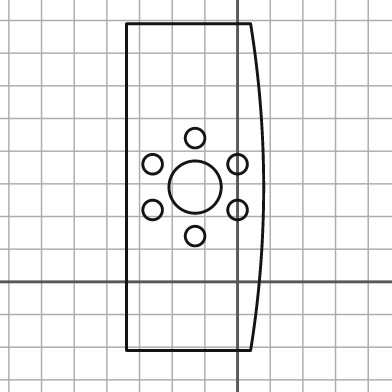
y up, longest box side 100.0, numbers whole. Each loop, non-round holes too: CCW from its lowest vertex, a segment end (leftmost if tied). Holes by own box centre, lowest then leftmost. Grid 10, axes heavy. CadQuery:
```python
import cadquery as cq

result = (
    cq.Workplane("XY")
    .moveTo(-34.0, -21.0)
    .lineTo(4.0, -21.0)
    .threePointArc((8.0, 29.0), (4.0, 79.0))
    .lineTo(-34.0, 79.0)
    .close()
    .moveTo(-13.0, 14.0)
    .circle(3.0)
    .moveTo(-26.0, 22.0)
    .circle(3.0)
    .moveTo(0.0, 22.0)
    .circle(3.0)
    .moveTo(-13.0, 29.0)
    .circle(8.0)
    .moveTo(-26.0, 36.0)
    .circle(3.0)
    .moveTo(0.0, 36.0)
    .circle(3.0)
    .moveTo(-13.0, 44.0)
    .circle(3.0)
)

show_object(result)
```